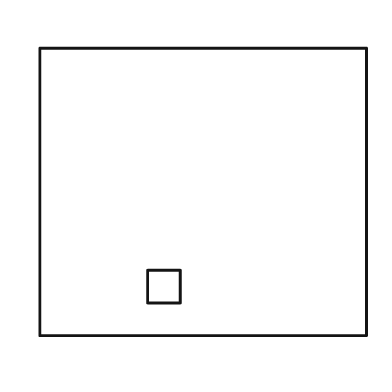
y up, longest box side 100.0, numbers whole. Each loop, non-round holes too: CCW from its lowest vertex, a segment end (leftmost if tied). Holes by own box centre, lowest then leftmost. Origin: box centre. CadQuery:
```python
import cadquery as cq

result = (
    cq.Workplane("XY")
    .moveTo(-50.0, -44.0)
    .lineTo(50.0, -44.0)
    .lineTo(50.0, 44.0)
    .lineTo(-50.0, 44.0)
    .close()
    .moveTo(-17.0, -34.0)
    .lineTo(-7.0, -34.0)
    .lineTo(-7.0, -24.0)
    .lineTo(-17.0, -24.0)
    .close()
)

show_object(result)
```